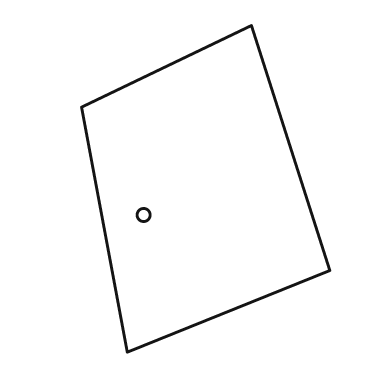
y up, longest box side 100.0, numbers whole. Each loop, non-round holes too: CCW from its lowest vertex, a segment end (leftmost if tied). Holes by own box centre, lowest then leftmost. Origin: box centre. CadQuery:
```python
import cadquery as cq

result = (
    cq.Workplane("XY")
    .moveTo(-24.0, -50.0)
    .lineTo(38.0, -25.0)
    .lineTo(14.0, 50.0)
    .lineTo(-38.0, 25.0)
    .close()
    .moveTo(-19.0, -8.0)
    .circle(2.0)
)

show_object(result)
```